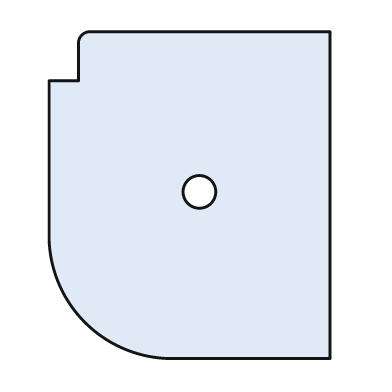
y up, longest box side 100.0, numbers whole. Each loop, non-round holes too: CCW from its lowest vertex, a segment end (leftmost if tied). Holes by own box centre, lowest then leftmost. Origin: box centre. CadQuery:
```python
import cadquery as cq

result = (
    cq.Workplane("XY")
    .moveTo(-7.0, -50.0)
    .lineTo(43.0, -50.0)
    .lineTo(43.0, 50.0)
    .lineTo(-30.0, 50.0)
    .threePointArc((-33.0, 49.0), (-34.0, 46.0))
    .lineTo(-34.0, 35.0)
    .lineTo(-43.0, 35.0)
    .lineTo(-43.0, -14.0)
    .threePointArc((-32.0, -39.0), (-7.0, -50.0))
    .close()
    .moveTo(3.0, 1.0)
    .circle(5.0)
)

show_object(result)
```